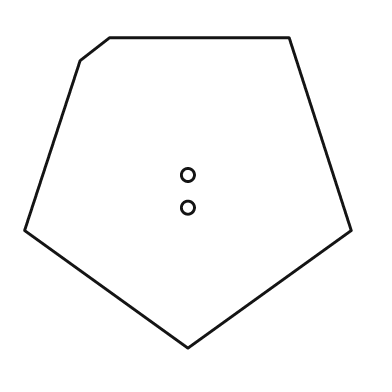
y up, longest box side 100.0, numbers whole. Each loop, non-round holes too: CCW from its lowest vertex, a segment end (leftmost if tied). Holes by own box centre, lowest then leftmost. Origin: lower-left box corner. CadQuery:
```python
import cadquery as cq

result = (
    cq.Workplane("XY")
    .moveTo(50.0, 0.0)
    .lineTo(100.0, 36.0)
    .lineTo(81.0, 95.0)
    .lineTo(26.0, 95.0)
    .lineTo(17.0, 88.0)
    .lineTo(0.0, 36.0)
    .close()
    .moveTo(50.0, 43.0)
    .circle(2.0)
    .moveTo(50.0, 53.0)
    .circle(2.0)
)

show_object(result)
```